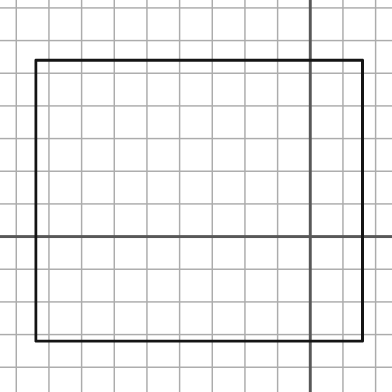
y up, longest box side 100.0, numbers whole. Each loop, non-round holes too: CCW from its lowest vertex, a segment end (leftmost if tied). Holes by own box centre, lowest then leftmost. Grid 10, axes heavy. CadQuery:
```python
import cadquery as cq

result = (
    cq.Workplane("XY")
    .moveTo(-84.0, -32.0)
    .lineTo(16.0, -32.0)
    .lineTo(16.0, 54.0)
    .lineTo(-84.0, 54.0)
    .close()
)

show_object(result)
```